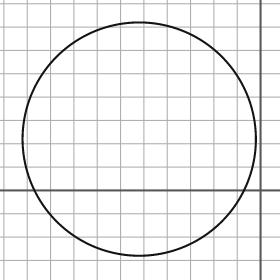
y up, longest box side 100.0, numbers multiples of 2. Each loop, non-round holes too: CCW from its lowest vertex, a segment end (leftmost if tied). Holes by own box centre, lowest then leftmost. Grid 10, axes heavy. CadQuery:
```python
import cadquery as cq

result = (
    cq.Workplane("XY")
    .moveTo(-52.0, 22.0)
    .circle(50.0)
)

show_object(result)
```